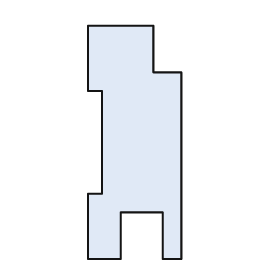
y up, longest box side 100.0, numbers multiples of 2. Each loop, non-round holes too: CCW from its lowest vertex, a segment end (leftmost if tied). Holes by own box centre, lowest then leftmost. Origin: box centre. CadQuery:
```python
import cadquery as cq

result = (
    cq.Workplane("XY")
    .moveTo(-20.0, -50.0)
    .lineTo(-6.0, -50.0)
    .lineTo(-6.0, -30.0)
    .lineTo(12.0, -30.0)
    .lineTo(12.0, -50.0)
    .lineTo(20.0, -50.0)
    .lineTo(20.0, 30.0)
    .lineTo(8.0, 30.0)
    .lineTo(8.0, 50.0)
    .lineTo(-20.0, 50.0)
    .lineTo(-20.0, 22.0)
    .lineTo(-14.0, 22.0)
    .lineTo(-14.0, -22.0)
    .lineTo(-20.0, -22.0)
    .close()
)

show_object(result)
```